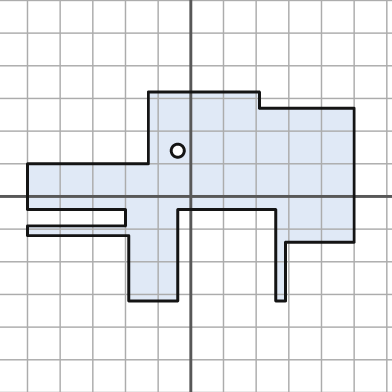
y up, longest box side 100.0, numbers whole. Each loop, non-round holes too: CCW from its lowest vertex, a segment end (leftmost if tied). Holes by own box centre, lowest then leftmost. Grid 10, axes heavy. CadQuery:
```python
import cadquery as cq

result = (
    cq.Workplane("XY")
    .moveTo(-19.0, -32.0)
    .lineTo(-4.0, -32.0)
    .lineTo(-4.0, -4.0)
    .lineTo(26.0, -4.0)
    .lineTo(26.0, -32.0)
    .lineTo(29.0, -32.0)
    .lineTo(29.0, -14.0)
    .lineTo(50.0, -14.0)
    .lineTo(50.0, 27.0)
    .lineTo(21.0, 27.0)
    .lineTo(21.0, 32.0)
    .lineTo(-13.0, 32.0)
    .lineTo(-13.0, 10.0)
    .lineTo(-50.0, 10.0)
    .lineTo(-50.0, -4.0)
    .lineTo(-20.0, -4.0)
    .lineTo(-20.0, -9.0)
    .lineTo(-50.0, -9.0)
    .lineTo(-50.0, -12.0)
    .lineTo(-19.0, -12.0)
    .close()
    .moveTo(-4.0, 14.0)
    .circle(2.0)
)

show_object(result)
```